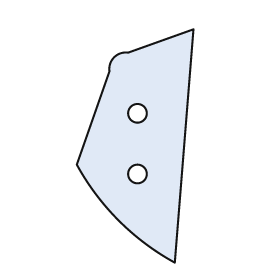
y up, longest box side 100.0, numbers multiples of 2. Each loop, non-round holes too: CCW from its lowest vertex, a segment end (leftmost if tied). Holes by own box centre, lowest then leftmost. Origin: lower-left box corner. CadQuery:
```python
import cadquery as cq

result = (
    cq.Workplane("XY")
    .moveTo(42.0, 0.0)
    .lineTo(50.0, 100.0)
    .lineTo(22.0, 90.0)
    .threePointArc((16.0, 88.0), (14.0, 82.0))
    .lineTo(0.0, 42.0)
    .threePointArc((18.0, 18.0), (42.0, 0.0))
    .close()
    .moveTo(26.0, 38.0)
    .circle(4.0)
    .moveTo(26.0, 64.0)
    .circle(4.0)
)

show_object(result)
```